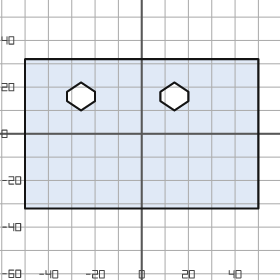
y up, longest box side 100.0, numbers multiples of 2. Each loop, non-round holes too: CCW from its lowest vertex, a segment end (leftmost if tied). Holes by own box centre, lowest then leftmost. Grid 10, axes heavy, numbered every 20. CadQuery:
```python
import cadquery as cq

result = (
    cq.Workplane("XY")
    .moveTo(-50.0, -32.0)
    .lineTo(50.0, -32.0)
    .lineTo(50.0, 32.0)
    .lineTo(-50.0, 32.0)
    .close()
    .moveTo(-26.0, 10.0)
    .lineTo(-20.0, 14.0)
    .lineTo(-20.0, 18.0)
    .lineTo(-26.0, 22.0)
    .lineTo(-32.0, 18.0)
    .lineTo(-32.0, 14.0)
    .close()
    .moveTo(14.0, 10.0)
    .lineTo(20.0, 14.0)
    .lineTo(20.0, 18.0)
    .lineTo(14.0, 22.0)
    .lineTo(8.0, 18.0)
    .lineTo(8.0, 14.0)
    .close()
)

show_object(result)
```